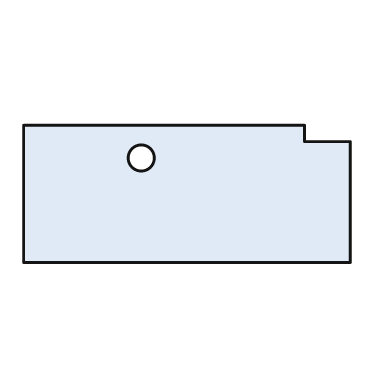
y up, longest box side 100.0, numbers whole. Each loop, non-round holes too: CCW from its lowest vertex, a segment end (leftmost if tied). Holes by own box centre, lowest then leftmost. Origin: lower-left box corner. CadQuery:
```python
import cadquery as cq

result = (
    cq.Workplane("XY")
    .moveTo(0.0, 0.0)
    .lineTo(100.0, 0.0)
    .lineTo(100.0, 37.0)
    .lineTo(86.0, 37.0)
    .lineTo(86.0, 42.0)
    .lineTo(0.0, 42.0)
    .close()
    .moveTo(36.0, 32.0)
    .circle(4.0)
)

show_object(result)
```